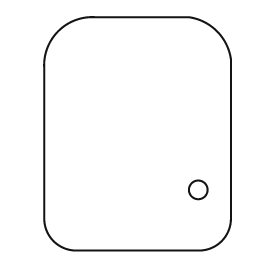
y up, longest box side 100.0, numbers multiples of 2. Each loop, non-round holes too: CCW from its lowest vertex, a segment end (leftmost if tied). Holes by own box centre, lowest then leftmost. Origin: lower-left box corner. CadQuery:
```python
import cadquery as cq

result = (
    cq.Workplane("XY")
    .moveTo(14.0, 0.0)
    .lineTo(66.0, 0.0)
    .threePointArc((76.0, 4.0), (80.0, 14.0))
    .lineTo(80.0, 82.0)
    .threePointArc((74.0, 94.0), (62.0, 100.0))
    .lineTo(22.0, 100.0)
    .threePointArc((6.0, 94.0), (0.0, 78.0))
    .lineTo(0.0, 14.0)
    .threePointArc((4.0, 4.0), (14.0, 0.0))
    .close()
    .moveTo(66.0, 26.0)
    .circle(4.0)
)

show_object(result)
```